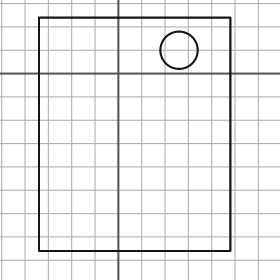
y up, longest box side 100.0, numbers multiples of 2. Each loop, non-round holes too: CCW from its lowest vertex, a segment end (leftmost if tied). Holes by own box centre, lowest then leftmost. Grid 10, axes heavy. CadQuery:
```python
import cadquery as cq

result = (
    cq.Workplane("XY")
    .moveTo(-34.0, -76.0)
    .lineTo(48.0, -76.0)
    .lineTo(48.0, 24.0)
    .lineTo(-34.0, 24.0)
    .close()
    .moveTo(26.0, 10.0)
    .circle(8.0)
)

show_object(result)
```